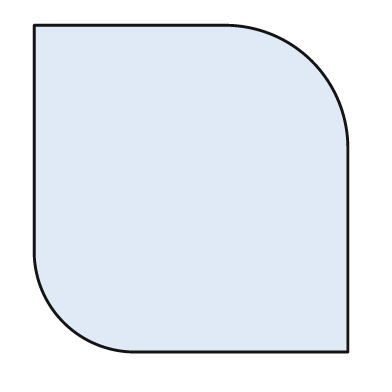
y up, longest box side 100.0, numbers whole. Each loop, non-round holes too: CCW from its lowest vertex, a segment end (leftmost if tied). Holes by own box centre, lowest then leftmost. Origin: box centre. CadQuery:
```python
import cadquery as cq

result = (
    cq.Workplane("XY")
    .moveTo(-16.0, -50.0)
    .lineTo(48.0, -50.0)
    .lineTo(48.0, 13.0)
    .threePointArc((37.0, 39.0), (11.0, 50.0))
    .lineTo(-48.0, 50.0)
    .lineTo(-48.0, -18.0)
    .threePointArc((-39.0, -41.0), (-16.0, -50.0))
    .close()
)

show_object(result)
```